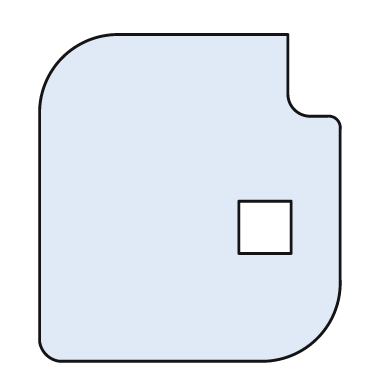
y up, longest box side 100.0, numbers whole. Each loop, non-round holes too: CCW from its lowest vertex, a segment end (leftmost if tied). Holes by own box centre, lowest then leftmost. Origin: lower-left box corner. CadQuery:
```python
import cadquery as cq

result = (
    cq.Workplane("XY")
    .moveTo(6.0, 0.0)
    .lineTo(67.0, 0.0)
    .threePointArc((85.0, 7.0), (92.0, 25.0))
    .lineTo(92.0, 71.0)
    .threePointArc((91.0, 74.0), (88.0, 75.0))
    .lineTo(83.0, 75.0)
    .threePointArc((78.0, 77.0), (76.0, 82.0))
    .lineTo(76.0, 100.0)
    .lineTo(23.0, 100.0)
    .threePointArc((7.0, 93.0), (0.0, 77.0))
    .lineTo(0.0, 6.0)
    .threePointArc((2.0, 2.0), (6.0, 0.0))
    .close()
    .moveTo(61.0, 33.0)
    .lineTo(77.0, 33.0)
    .lineTo(77.0, 49.0)
    .lineTo(61.0, 49.0)
    .close()
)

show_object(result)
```